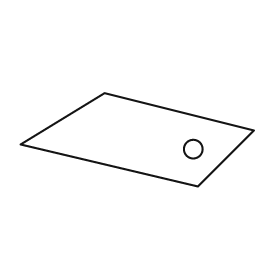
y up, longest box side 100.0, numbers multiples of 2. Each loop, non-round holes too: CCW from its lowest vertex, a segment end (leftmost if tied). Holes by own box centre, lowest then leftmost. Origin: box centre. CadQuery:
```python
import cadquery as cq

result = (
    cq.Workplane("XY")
    .moveTo(26.0, -20.0)
    .lineTo(50.0, 4.0)
    .lineTo(-14.0, 20.0)
    .lineTo(-50.0, -2.0)
    .close()
    .moveTo(24.0, -4.0)
    .circle(4.0)
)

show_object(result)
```